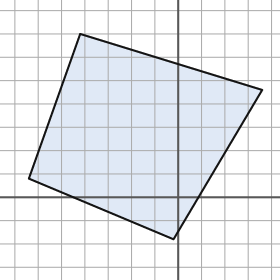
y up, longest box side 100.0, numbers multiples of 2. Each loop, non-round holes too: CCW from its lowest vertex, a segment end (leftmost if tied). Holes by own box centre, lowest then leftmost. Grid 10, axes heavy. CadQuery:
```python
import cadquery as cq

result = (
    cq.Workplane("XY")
    .moveTo(-2.0, -18.0)
    .lineTo(36.0, 46.0)
    .lineTo(-42.0, 70.0)
    .lineTo(-64.0, 8.0)
    .close()
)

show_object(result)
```